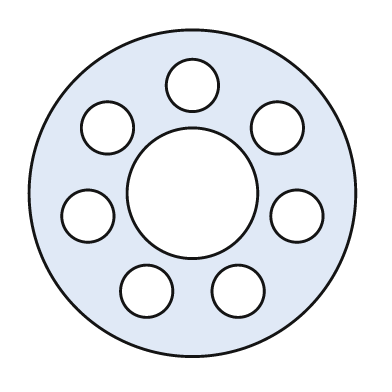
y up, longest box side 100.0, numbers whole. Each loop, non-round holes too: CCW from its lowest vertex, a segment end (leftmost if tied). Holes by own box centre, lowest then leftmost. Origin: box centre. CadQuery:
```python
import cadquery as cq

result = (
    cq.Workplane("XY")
    .moveTo(0.0, 0.0)
    .circle(50.0)
    .moveTo(-14.0, -30.0)
    .circle(8.0)
    .moveTo(14.0, -30.0)
    .circle(8.0)
    .moveTo(-32.0, -7.0)
    .circle(8.0)
    .moveTo(32.0, -7.0)
    .circle(8.0)
    .moveTo(0.0, 0.0)
    .circle(20.0)
    .moveTo(-26.0, 20.0)
    .circle(8.0)
    .moveTo(26.0, 20.0)
    .circle(8.0)
    .moveTo(0.0, 33.0)
    .circle(8.0)
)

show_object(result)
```